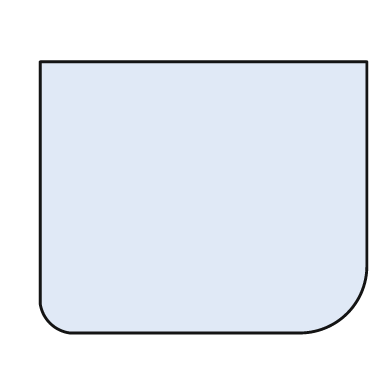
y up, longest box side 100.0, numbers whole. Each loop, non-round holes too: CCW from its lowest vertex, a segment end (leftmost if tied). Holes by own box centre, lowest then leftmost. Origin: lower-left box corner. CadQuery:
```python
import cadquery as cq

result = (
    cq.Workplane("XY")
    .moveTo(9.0, 0.0)
    .lineTo(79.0, 0.0)
    .threePointArc((94.0, 6.0), (100.0, 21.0))
    .lineTo(100.0, 83.0)
    .lineTo(0.0, 83.0)
    .lineTo(0.0, 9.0)
    .threePointArc((3.0, 3.0), (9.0, 0.0))
    .close()
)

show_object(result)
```